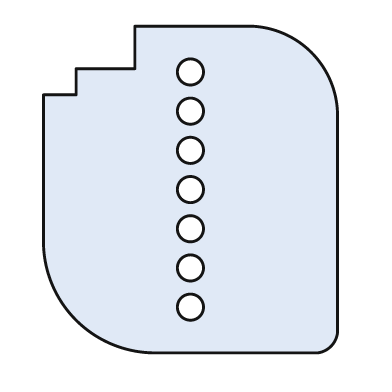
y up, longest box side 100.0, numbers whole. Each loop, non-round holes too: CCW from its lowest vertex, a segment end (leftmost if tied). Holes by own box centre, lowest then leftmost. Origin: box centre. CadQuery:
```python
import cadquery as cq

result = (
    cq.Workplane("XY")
    .moveTo(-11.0, -50.0)
    .lineTo(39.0, -50.0)
    .threePointArc((43.0, -48.0), (45.0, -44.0))
    .lineTo(45.0, 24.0)
    .threePointArc((37.0, 42.0), (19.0, 50.0))
    .lineTo(-17.0, 50.0)
    .lineTo(-17.0, 37.0)
    .lineTo(-35.0, 37.0)
    .lineTo(-35.0, 29.0)
    .lineTo(-45.0, 29.0)
    .lineTo(-45.0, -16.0)
    .threePointArc((-35.0, -40.0), (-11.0, -50.0))
    .close()
    .moveTo(0.0, -36.0)
    .circle(4.0)
    .moveTo(0.0, -24.0)
    .circle(4.0)
    .moveTo(0.0, -12.0)
    .circle(4.0)
    .moveTo(0.0, 0.0)
    .circle(4.0)
    .moveTo(0.0, 12.0)
    .circle(4.0)
    .moveTo(0.0, 24.0)
    .circle(4.0)
    .moveTo(0.0, 36.0)
    .circle(4.0)
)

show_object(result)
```